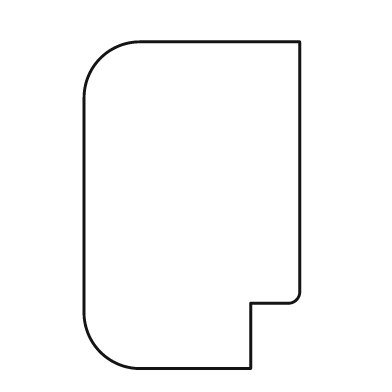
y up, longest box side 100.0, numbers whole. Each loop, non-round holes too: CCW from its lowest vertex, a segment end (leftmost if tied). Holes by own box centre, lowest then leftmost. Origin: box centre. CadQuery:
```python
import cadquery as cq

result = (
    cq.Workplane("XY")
    .moveTo(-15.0, -50.0)
    .lineTo(18.0, -50.0)
    .lineTo(18.0, -30.0)
    .lineTo(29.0, -30.0)
    .threePointArc((32.0, -29.0), (33.0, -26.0))
    .lineTo(33.0, 50.0)
    .lineTo(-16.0, 50.0)
    .threePointArc((-28.0, 45.0), (-33.0, 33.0))
    .lineTo(-33.0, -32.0)
    .threePointArc((-28.0, -45.0), (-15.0, -50.0))
    .close()
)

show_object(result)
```